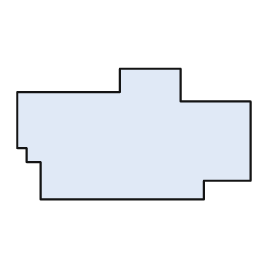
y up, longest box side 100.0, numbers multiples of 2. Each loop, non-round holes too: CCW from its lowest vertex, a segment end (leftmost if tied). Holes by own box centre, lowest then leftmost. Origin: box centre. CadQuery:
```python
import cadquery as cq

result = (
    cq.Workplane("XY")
    .moveTo(-40.0, -28.0)
    .lineTo(30.0, -28.0)
    .lineTo(30.0, -20.0)
    .lineTo(50.0, -20.0)
    .lineTo(50.0, 14.0)
    .lineTo(20.0, 14.0)
    .lineTo(20.0, 28.0)
    .lineTo(-6.0, 28.0)
    .lineTo(-6.0, 18.0)
    .lineTo(-50.0, 18.0)
    .lineTo(-50.0, -6.0)
    .lineTo(-46.0, -6.0)
    .lineTo(-46.0, -12.0)
    .lineTo(-40.0, -12.0)
    .close()
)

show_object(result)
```